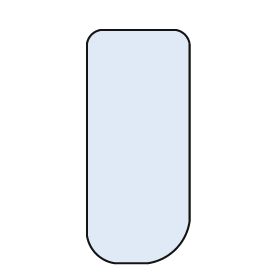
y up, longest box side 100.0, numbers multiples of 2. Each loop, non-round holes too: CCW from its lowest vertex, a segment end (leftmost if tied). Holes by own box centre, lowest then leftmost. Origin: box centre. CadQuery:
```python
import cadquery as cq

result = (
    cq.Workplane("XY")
    .moveTo(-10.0, -50.0)
    .lineTo(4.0, -50.0)
    .threePointArc((16.0, -44.0), (22.0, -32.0))
    .lineTo(22.0, 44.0)
    .threePointArc((20.0, 48.0), (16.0, 50.0))
    .lineTo(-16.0, 50.0)
    .threePointArc((-20.0, 48.0), (-22.0, 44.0))
    .lineTo(-22.0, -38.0)
    .threePointArc((-18.0, -46.0), (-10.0, -50.0))
    .close()
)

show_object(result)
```